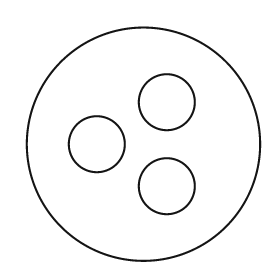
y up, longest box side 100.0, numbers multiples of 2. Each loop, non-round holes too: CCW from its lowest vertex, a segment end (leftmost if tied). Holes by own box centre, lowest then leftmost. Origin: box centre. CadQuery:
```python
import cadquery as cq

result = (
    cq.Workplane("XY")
    .moveTo(0.0, 0.0)
    .circle(50.0)
    .moveTo(10.0, -18.0)
    .circle(12.0)
    .moveTo(-20.0, 0.0)
    .circle(12.0)
    .moveTo(10.0, 18.0)
    .circle(12.0)
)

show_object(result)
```